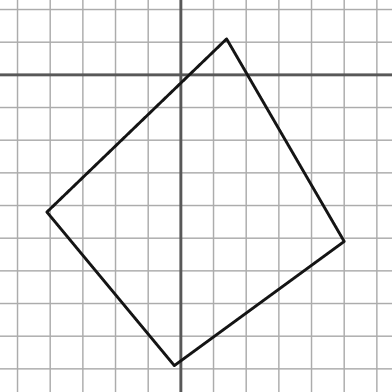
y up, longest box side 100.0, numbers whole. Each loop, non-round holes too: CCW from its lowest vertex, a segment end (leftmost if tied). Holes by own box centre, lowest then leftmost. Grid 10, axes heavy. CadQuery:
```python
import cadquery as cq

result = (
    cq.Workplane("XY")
    .moveTo(-2.0, -89.0)
    .lineTo(50.0, -51.0)
    .lineTo(14.0, 11.0)
    .lineTo(-41.0, -42.0)
    .close()
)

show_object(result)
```